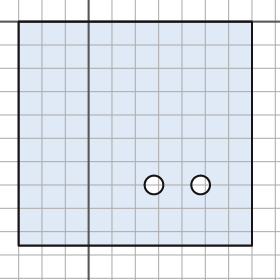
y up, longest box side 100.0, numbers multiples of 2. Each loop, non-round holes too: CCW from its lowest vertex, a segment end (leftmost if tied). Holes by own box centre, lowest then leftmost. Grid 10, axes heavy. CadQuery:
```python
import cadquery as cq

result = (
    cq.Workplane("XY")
    .moveTo(-30.0, -96.0)
    .lineTo(70.0, -96.0)
    .lineTo(70.0, 0.0)
    .lineTo(-30.0, 0.0)
    .close()
    .moveTo(28.0, -70.0)
    .circle(4.0)
    .moveTo(48.0, -70.0)
    .circle(4.0)
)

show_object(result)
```